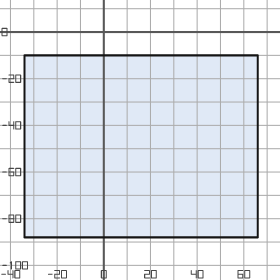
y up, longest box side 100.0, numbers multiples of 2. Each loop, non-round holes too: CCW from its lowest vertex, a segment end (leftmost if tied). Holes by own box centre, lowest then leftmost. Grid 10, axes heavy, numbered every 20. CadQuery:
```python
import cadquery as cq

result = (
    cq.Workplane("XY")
    .moveTo(-34.0, -88.0)
    .lineTo(66.0, -88.0)
    .lineTo(66.0, -10.0)
    .lineTo(-34.0, -10.0)
    .close()
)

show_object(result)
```